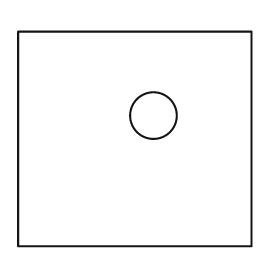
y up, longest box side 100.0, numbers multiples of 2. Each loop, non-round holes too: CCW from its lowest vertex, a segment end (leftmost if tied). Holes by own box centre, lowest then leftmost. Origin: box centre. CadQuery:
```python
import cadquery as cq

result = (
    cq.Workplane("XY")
    .moveTo(-50.0, -46.0)
    .lineTo(50.0, -46.0)
    .lineTo(50.0, 46.0)
    .lineTo(-50.0, 46.0)
    .close()
    .moveTo(8.0, 10.0)
    .circle(10.0)
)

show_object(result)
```